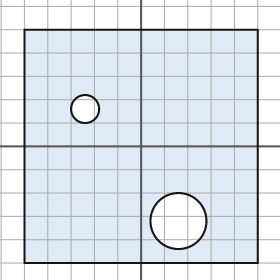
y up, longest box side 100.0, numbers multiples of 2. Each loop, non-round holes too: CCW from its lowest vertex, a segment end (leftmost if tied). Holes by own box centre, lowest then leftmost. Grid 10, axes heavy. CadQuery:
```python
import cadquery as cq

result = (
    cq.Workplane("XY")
    .moveTo(-50.0, -50.0)
    .lineTo(50.0, -50.0)
    .lineTo(50.0, 50.0)
    .lineTo(-50.0, 50.0)
    .close()
    .moveTo(16.0, -32.0)
    .circle(12.0)
    .moveTo(-24.0, 16.0)
    .circle(6.0)
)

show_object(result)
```